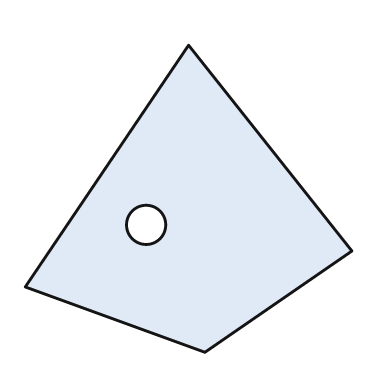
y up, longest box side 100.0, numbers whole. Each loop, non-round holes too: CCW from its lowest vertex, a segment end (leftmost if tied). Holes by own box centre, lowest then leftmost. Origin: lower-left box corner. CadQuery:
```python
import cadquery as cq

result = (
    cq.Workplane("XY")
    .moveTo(55.0, 0.0)
    .lineTo(100.0, 31.0)
    .lineTo(50.0, 94.0)
    .lineTo(0.0, 20.0)
    .close()
    .moveTo(37.0, 39.0)
    .circle(6.0)
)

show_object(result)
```